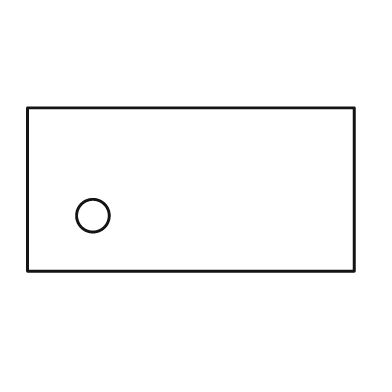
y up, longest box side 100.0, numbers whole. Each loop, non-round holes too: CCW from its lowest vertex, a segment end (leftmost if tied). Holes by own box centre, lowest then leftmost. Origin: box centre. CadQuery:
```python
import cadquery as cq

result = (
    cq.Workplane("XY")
    .moveTo(-50.0, -25.0)
    .lineTo(50.0, -25.0)
    .lineTo(50.0, 25.0)
    .lineTo(-50.0, 25.0)
    .close()
    .moveTo(-30.0, -8.0)
    .circle(5.0)
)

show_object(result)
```